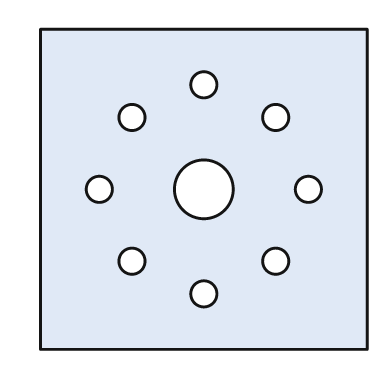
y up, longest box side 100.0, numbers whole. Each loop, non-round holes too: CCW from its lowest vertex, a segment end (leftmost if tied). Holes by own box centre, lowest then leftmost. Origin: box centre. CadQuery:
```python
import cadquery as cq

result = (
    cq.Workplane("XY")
    .moveTo(-50.0, -49.0)
    .lineTo(50.0, -49.0)
    .lineTo(50.0, 49.0)
    .lineTo(-50.0, 49.0)
    .close()
    .moveTo(0.0, -32.0)
    .circle(4.0)
    .moveTo(-22.0, -22.0)
    .circle(4.0)
    .moveTo(22.0, -22.0)
    .circle(4.0)
    .moveTo(-32.0, 0.0)
    .circle(4.0)
    .moveTo(0.0, 0.0)
    .circle(9.0)
    .moveTo(32.0, 0.0)
    .circle(4.0)
    .moveTo(-22.0, 22.0)
    .circle(4.0)
    .moveTo(22.0, 22.0)
    .circle(4.0)
    .moveTo(0.0, 32.0)
    .circle(4.0)
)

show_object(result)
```